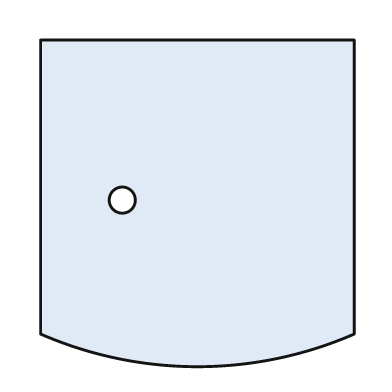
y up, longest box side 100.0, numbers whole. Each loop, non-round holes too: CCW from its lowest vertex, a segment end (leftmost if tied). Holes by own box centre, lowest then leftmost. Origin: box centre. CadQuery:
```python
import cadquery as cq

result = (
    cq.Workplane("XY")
    .moveTo(-48.0, -40.0)
    .threePointArc((0.0, -50.0), (48.0, -40.0))
    .lineTo(48.0, 50.0)
    .lineTo(-48.0, 50.0)
    .close()
    .moveTo(-23.0, 1.0)
    .circle(4.0)
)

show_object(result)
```